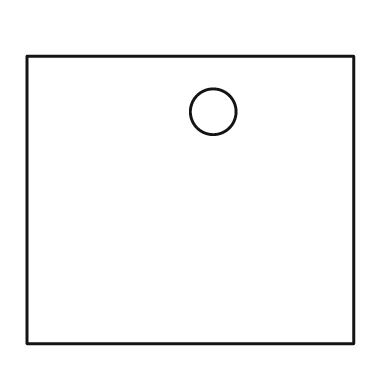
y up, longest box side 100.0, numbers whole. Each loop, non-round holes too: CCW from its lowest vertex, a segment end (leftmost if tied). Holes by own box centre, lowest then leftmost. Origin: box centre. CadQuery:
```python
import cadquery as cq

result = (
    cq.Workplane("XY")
    .moveTo(-50.0, -44.0)
    .lineTo(50.0, -44.0)
    .lineTo(50.0, 44.0)
    .lineTo(-50.0, 44.0)
    .close()
    .moveTo(7.0, 27.0)
    .circle(7.0)
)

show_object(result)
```